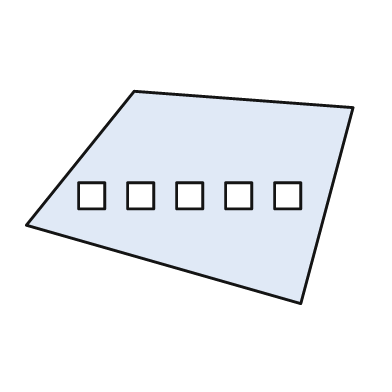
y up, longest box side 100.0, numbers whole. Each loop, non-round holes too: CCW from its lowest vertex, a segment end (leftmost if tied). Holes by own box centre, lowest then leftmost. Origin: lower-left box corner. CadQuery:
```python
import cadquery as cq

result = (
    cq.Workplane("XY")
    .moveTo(84.0, 0.0)
    .lineTo(100.0, 60.0)
    .lineTo(33.0, 65.0)
    .lineTo(0.0, 24.0)
    .close()
    .moveTo(16.0, 29.0)
    .lineTo(24.0, 29.0)
    .lineTo(24.0, 37.0)
    .lineTo(16.0, 37.0)
    .close()
    .moveTo(31.0, 29.0)
    .lineTo(39.0, 29.0)
    .lineTo(39.0, 37.0)
    .lineTo(31.0, 37.0)
    .close()
    .moveTo(46.0, 29.0)
    .lineTo(54.0, 29.0)
    .lineTo(54.0, 37.0)
    .lineTo(46.0, 37.0)
    .close()
    .moveTo(61.0, 29.0)
    .lineTo(69.0, 29.0)
    .lineTo(69.0, 37.0)
    .lineTo(61.0, 37.0)
    .close()
    .moveTo(76.0, 29.0)
    .lineTo(84.0, 29.0)
    .lineTo(84.0, 37.0)
    .lineTo(76.0, 37.0)
    .close()
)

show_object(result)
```